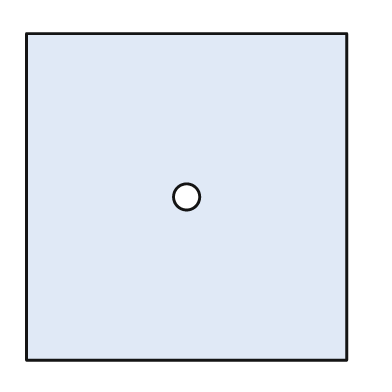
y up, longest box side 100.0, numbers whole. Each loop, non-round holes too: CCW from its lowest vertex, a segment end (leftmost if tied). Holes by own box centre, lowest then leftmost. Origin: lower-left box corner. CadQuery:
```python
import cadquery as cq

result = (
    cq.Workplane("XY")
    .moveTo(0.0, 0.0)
    .lineTo(98.0, 0.0)
    .lineTo(98.0, 100.0)
    .lineTo(0.0, 100.0)
    .close()
    .moveTo(49.0, 50.0)
    .circle(4.0)
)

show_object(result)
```